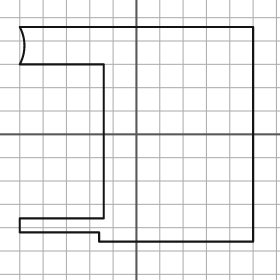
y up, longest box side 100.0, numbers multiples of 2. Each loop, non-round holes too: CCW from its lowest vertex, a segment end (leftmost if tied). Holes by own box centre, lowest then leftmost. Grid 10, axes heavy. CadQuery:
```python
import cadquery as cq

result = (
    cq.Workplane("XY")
    .moveTo(-16.0, -46.0)
    .lineTo(50.0, -46.0)
    .lineTo(50.0, 46.0)
    .lineTo(-50.0, 46.0)
    .threePointArc((-48.0, 38.0), (-50.0, 30.0))
    .lineTo(-14.0, 30.0)
    .lineTo(-14.0, -36.0)
    .lineTo(-50.0, -36.0)
    .lineTo(-50.0, -42.0)
    .lineTo(-16.0, -42.0)
    .close()
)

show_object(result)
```